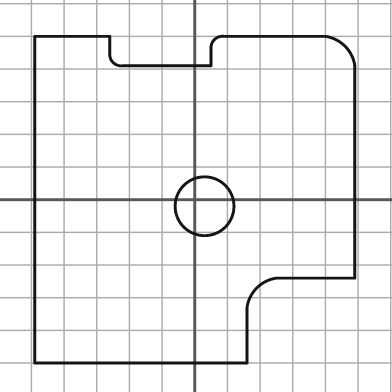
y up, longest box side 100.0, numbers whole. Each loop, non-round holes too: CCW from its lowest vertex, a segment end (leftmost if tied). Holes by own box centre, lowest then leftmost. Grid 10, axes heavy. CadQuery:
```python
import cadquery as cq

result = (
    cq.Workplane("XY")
    .moveTo(-49.0, -50.0)
    .lineTo(16.0, -50.0)
    .lineTo(16.0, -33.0)
    .threePointArc((19.0, -27.0), (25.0, -24.0))
    .lineTo(49.0, -24.0)
    .lineTo(49.0, 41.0)
    .threePointArc((46.0, 47.0), (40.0, 50.0))
    .lineTo(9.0, 50.0)
    .threePointArc((6.0, 49.0), (5.0, 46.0))
    .lineTo(5.0, 41.0)
    .lineTo(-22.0, 41.0)
    .threePointArc((-25.0, 42.0), (-26.0, 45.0))
    .lineTo(-26.0, 50.0)
    .lineTo(-49.0, 50.0)
    .close()
    .moveTo(3.0, -2.0)
    .circle(9.0)
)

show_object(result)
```